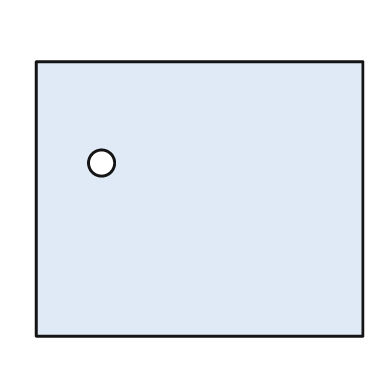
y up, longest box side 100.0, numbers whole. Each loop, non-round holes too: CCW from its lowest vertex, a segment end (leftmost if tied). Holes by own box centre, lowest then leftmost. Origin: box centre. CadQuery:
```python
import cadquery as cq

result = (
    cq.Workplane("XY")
    .moveTo(-50.0, -42.0)
    .lineTo(50.0, -42.0)
    .lineTo(50.0, 42.0)
    .lineTo(-50.0, 42.0)
    .close()
    .moveTo(-30.0, 11.0)
    .circle(4.0)
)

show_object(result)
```